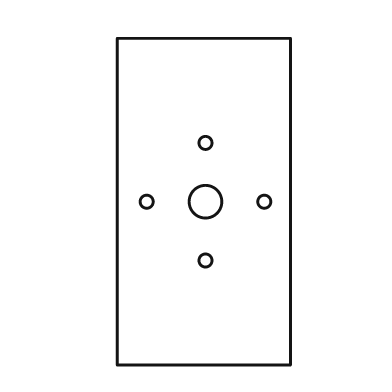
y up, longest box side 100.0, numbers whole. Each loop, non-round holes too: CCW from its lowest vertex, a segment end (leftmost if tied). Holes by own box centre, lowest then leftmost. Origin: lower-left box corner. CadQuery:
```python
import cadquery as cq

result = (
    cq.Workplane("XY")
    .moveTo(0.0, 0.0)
    .lineTo(53.0, 0.0)
    .lineTo(53.0, 100.0)
    .lineTo(0.0, 100.0)
    .close()
    .moveTo(27.0, 32.0)
    .circle(2.0)
    .moveTo(9.0, 50.0)
    .circle(2.0)
    .moveTo(27.0, 50.0)
    .circle(5.0)
    .moveTo(45.0, 50.0)
    .circle(2.0)
    .moveTo(27.0, 68.0)
    .circle(2.0)
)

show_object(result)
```